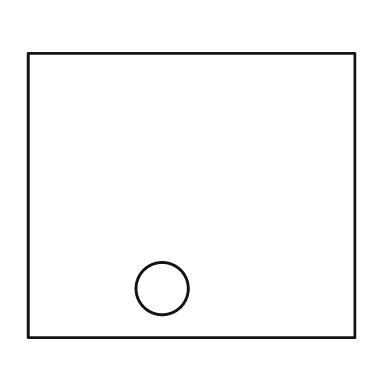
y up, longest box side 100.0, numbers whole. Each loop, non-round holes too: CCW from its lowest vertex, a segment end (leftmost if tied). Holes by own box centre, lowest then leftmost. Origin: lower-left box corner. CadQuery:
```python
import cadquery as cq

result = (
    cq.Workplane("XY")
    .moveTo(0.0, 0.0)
    .lineTo(100.0, 0.0)
    .lineTo(100.0, 87.0)
    .lineTo(0.0, 87.0)
    .close()
    .moveTo(41.0, 15.0)
    .circle(8.0)
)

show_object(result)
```